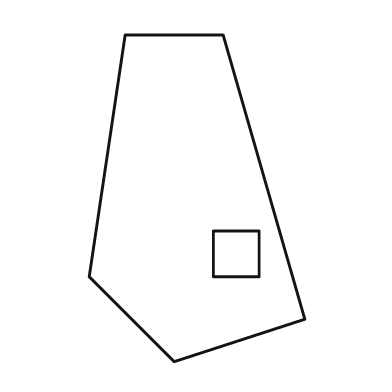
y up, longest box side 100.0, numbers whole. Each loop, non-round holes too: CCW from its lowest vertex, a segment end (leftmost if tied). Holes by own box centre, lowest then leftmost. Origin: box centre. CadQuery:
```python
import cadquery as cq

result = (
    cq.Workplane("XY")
    .moveTo(-7.0, -50.0)
    .lineTo(33.0, -37.0)
    .lineTo(8.0, 50.0)
    .lineTo(-22.0, 50.0)
    .lineTo(-33.0, -24.0)
    .close()
    .moveTo(5.0, -24.0)
    .lineTo(19.0, -24.0)
    .lineTo(19.0, -10.0)
    .lineTo(5.0, -10.0)
    .close()
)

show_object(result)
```